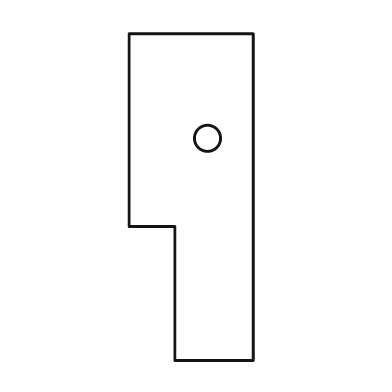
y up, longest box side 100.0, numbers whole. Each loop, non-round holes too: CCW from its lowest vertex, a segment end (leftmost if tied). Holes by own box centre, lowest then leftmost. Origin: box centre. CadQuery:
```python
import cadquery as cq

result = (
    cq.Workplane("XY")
    .moveTo(-5.0, -50.0)
    .lineTo(19.0, -50.0)
    .lineTo(19.0, 50.0)
    .lineTo(-19.0, 50.0)
    .lineTo(-19.0, -9.0)
    .lineTo(-5.0, -9.0)
    .close()
    .moveTo(5.0, 18.0)
    .circle(4.0)
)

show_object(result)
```